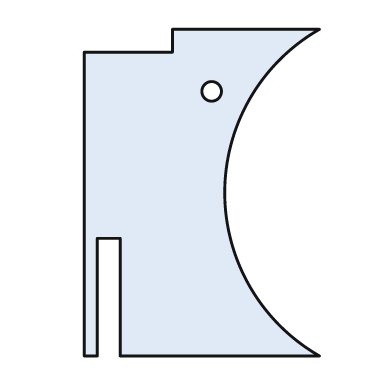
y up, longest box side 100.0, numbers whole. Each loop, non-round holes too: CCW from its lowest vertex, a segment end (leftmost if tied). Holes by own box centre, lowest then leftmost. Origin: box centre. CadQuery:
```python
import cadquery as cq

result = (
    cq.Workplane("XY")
    .moveTo(-36.0, -50.0)
    .lineTo(-32.0, -50.0)
    .lineTo(-32.0, -14.0)
    .lineTo(-25.0, -14.0)
    .lineTo(-25.0, -50.0)
    .lineTo(36.0, -50.0)
    .threePointArc((7.0, 0.0), (36.0, 50.0))
    .lineTo(-9.0, 50.0)
    .lineTo(-9.0, 43.0)
    .lineTo(-36.0, 43.0)
    .close()
    .moveTo(3.0, 31.0)
    .circle(3.0)
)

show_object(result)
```